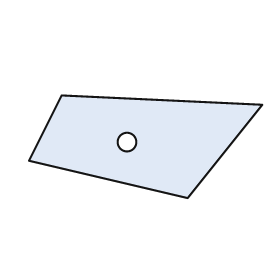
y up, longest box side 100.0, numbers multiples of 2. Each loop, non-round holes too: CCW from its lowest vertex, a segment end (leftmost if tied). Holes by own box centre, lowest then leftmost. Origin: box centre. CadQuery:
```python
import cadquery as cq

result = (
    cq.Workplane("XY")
    .moveTo(18.0, -22.0)
    .lineTo(50.0, 18.0)
    .lineTo(-36.0, 22.0)
    .lineTo(-50.0, -6.0)
    .close()
    .moveTo(-8.0, 2.0)
    .circle(4.0)
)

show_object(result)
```